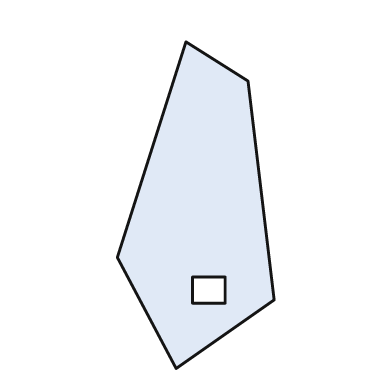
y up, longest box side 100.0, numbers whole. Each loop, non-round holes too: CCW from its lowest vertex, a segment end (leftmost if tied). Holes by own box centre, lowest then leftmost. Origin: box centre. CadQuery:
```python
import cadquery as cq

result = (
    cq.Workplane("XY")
    .moveTo(-6.0, -50.0)
    .lineTo(24.0, -29.0)
    .lineTo(16.0, 38.0)
    .lineTo(-3.0, 50.0)
    .lineTo(-24.0, -16.0)
    .close()
    .moveTo(-1.0, -30.0)
    .lineTo(9.0, -30.0)
    .lineTo(9.0, -22.0)
    .lineTo(-1.0, -22.0)
    .close()
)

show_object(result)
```